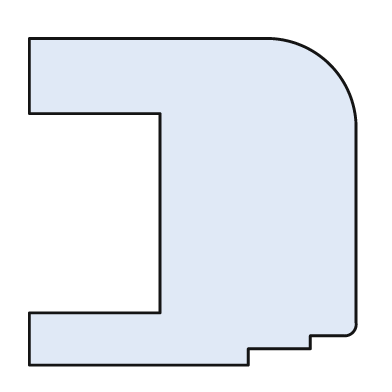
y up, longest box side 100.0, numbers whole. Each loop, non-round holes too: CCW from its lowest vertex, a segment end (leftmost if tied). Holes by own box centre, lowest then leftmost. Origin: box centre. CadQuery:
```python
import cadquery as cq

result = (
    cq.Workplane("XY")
    .moveTo(-50.0, -50.0)
    .lineTo(17.0, -50.0)
    .lineTo(17.0, -45.0)
    .lineTo(36.0, -45.0)
    .lineTo(36.0, -41.0)
    .lineTo(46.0, -41.0)
    .threePointArc((49.0, -40.0), (50.0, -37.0))
    .lineTo(50.0, 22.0)
    .threePointArc((42.0, 42.0), (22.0, 50.0))
    .lineTo(-50.0, 50.0)
    .lineTo(-50.0, 27.0)
    .lineTo(-10.0, 27.0)
    .lineTo(-10.0, -34.0)
    .lineTo(-50.0, -34.0)
    .close()
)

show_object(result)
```